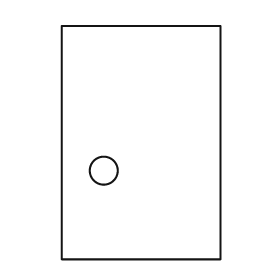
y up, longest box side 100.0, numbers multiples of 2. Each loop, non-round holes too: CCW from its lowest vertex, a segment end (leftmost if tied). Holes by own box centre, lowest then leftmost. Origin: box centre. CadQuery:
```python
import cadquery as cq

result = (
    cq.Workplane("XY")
    .moveTo(-34.0, -50.0)
    .lineTo(34.0, -50.0)
    .lineTo(34.0, 50.0)
    .lineTo(-34.0, 50.0)
    .close()
    .moveTo(-16.0, -12.0)
    .circle(6.0)
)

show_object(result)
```